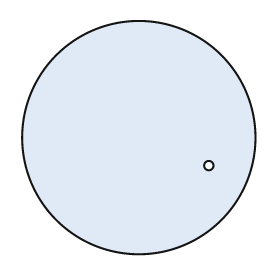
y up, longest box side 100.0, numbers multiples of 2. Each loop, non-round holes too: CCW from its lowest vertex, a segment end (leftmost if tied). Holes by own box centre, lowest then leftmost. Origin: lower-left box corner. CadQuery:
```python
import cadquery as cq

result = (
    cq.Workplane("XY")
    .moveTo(50.0, 50.0)
    .circle(50.0)
    .moveTo(80.0, 38.0)
    .circle(2.0)
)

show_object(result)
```